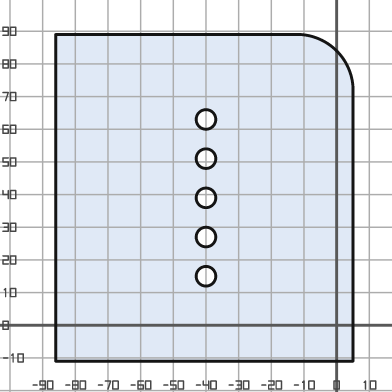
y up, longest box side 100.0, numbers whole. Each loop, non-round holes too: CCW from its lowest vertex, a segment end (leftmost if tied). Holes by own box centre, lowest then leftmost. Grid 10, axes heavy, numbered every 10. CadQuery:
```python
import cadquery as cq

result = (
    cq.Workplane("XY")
    .moveTo(-86.0, -11.0)
    .lineTo(5.0, -11.0)
    .lineTo(5.0, 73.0)
    .threePointArc((0.0, 84.0), (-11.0, 89.0))
    .lineTo(-86.0, 89.0)
    .close()
    .moveTo(-40.0, 15.0)
    .circle(3.0)
    .moveTo(-40.0, 27.0)
    .circle(3.0)
    .moveTo(-40.0, 39.0)
    .circle(3.0)
    .moveTo(-40.0, 51.0)
    .circle(3.0)
    .moveTo(-40.0, 63.0)
    .circle(3.0)
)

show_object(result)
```